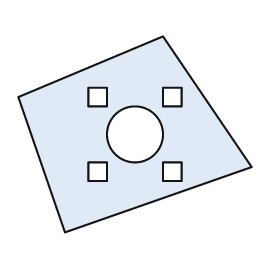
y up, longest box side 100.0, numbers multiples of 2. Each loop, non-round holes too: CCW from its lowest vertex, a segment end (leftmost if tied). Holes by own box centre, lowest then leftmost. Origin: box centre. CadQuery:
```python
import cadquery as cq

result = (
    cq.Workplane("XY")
    .moveTo(-30.0, -42.0)
    .lineTo(50.0, -14.0)
    .lineTo(12.0, 42.0)
    .lineTo(-50.0, 16.0)
    .close()
    .moveTo(-20.0, -20.0)
    .lineTo(-12.0, -20.0)
    .lineTo(-12.0, -12.0)
    .lineTo(-20.0, -12.0)
    .close()
    .moveTo(12.0, -20.0)
    .lineTo(20.0, -20.0)
    .lineTo(20.0, -12.0)
    .lineTo(12.0, -12.0)
    .close()
    .moveTo(0.0, 0.0)
    .circle(12.0)
    .moveTo(-20.0, 12.0)
    .lineTo(-12.0, 12.0)
    .lineTo(-12.0, 20.0)
    .lineTo(-20.0, 20.0)
    .close()
    .moveTo(12.0, 12.0)
    .lineTo(20.0, 12.0)
    .lineTo(20.0, 20.0)
    .lineTo(12.0, 20.0)
    .close()
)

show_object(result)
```